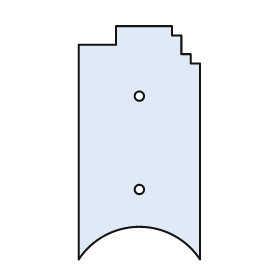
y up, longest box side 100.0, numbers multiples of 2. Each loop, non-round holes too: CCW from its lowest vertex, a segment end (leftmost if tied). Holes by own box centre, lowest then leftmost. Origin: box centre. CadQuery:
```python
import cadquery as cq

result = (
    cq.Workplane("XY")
    .moveTo(-26.0, -50.0)
    .threePointArc((0.0, -36.0), (26.0, -50.0))
    .lineTo(26.0, 34.0)
    .lineTo(22.0, 34.0)
    .lineTo(22.0, 38.0)
    .lineTo(18.0, 38.0)
    .lineTo(18.0, 46.0)
    .lineTo(14.0, 46.0)
    .lineTo(14.0, 50.0)
    .lineTo(-10.0, 50.0)
    .lineTo(-10.0, 42.0)
    .lineTo(-26.0, 42.0)
    .close()
    .moveTo(0.0, -20.0)
    .circle(2.0)
    .moveTo(0.0, 20.0)
    .circle(2.0)
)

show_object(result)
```